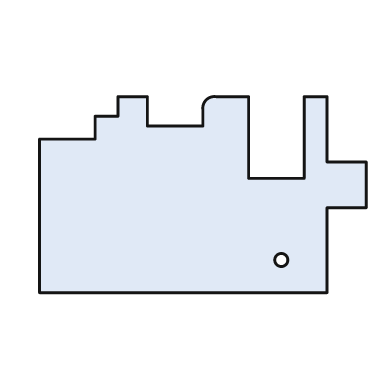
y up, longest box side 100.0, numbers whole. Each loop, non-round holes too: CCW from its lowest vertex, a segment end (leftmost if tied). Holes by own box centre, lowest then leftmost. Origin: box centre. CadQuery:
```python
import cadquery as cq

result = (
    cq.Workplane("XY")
    .moveTo(-50.0, -30.0)
    .lineTo(38.0, -30.0)
    .lineTo(38.0, -4.0)
    .lineTo(50.0, -4.0)
    .lineTo(50.0, 10.0)
    .lineTo(38.0, 10.0)
    .lineTo(38.0, 30.0)
    .lineTo(31.0, 30.0)
    .lineTo(31.0, 5.0)
    .lineTo(14.0, 5.0)
    .lineTo(14.0, 30.0)
    .lineTo(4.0, 30.0)
    .threePointArc((1.0, 29.0), (0.0, 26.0))
    .lineTo(0.0, 21.0)
    .lineTo(-17.0, 21.0)
    .lineTo(-17.0, 30.0)
    .lineTo(-26.0, 30.0)
    .lineTo(-26.0, 24.0)
    .lineTo(-33.0, 24.0)
    .lineTo(-33.0, 17.0)
    .lineTo(-50.0, 17.0)
    .close()
    .moveTo(24.0, -20.0)
    .circle(2.0)
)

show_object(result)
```